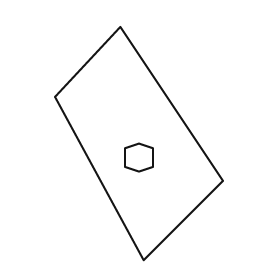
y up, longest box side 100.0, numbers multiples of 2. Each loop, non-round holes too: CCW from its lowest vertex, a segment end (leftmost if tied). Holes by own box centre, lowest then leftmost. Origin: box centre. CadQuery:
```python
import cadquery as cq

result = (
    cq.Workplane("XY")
    .moveTo(2.0, -50.0)
    .lineTo(36.0, -16.0)
    .lineTo(-8.0, 50.0)
    .lineTo(-36.0, 20.0)
    .close()
    .moveTo(0.0, -12.0)
    .lineTo(6.0, -10.0)
    .lineTo(6.0, -2.0)
    .lineTo(0.0, 0.0)
    .lineTo(-6.0, -2.0)
    .lineTo(-6.0, -10.0)
    .close()
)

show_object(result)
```